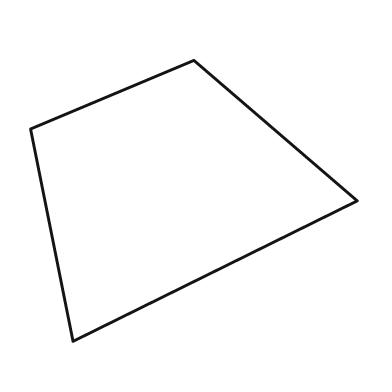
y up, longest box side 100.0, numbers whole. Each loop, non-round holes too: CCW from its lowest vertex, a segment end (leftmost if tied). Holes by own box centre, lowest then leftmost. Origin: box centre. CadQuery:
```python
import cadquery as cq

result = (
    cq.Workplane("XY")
    .moveTo(-37.0, -43.0)
    .lineTo(50.0, 0.0)
    .lineTo(0.0, 43.0)
    .lineTo(-50.0, 22.0)
    .close()
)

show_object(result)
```